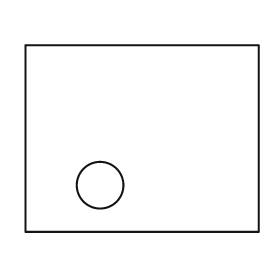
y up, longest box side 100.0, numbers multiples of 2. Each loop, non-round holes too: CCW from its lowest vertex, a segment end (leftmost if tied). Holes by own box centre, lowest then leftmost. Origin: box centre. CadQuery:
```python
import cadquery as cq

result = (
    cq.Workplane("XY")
    .moveTo(-50.0, -40.0)
    .lineTo(50.0, -40.0)
    .lineTo(50.0, 40.0)
    .lineTo(-50.0, 40.0)
    .close()
    .moveTo(-18.0, -20.0)
    .circle(10.0)
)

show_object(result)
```